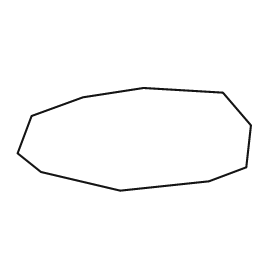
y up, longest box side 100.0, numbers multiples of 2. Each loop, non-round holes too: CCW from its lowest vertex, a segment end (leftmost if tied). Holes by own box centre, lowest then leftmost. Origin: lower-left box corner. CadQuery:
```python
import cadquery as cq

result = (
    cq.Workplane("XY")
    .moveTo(44.0, 0.0)
    .lineTo(82.0, 4.0)
    .lineTo(98.0, 10.0)
    .lineTo(100.0, 28.0)
    .lineTo(88.0, 42.0)
    .lineTo(54.0, 44.0)
    .lineTo(28.0, 40.0)
    .lineTo(6.0, 32.0)
    .lineTo(0.0, 16.0)
    .lineTo(10.0, 8.0)
    .close()
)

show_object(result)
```